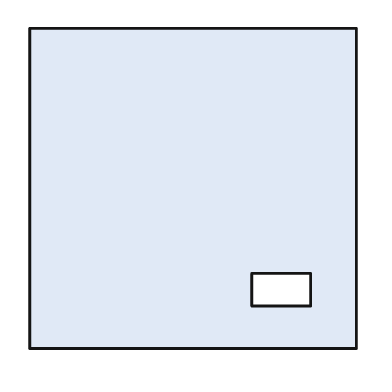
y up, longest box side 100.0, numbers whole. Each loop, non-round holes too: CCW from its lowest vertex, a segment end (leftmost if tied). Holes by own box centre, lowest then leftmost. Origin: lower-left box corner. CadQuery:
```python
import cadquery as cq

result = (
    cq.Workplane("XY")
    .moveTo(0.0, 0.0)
    .lineTo(100.0, 0.0)
    .lineTo(100.0, 98.0)
    .lineTo(0.0, 98.0)
    .close()
    .moveTo(68.0, 13.0)
    .lineTo(86.0, 13.0)
    .lineTo(86.0, 23.0)
    .lineTo(68.0, 23.0)
    .close()
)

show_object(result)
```